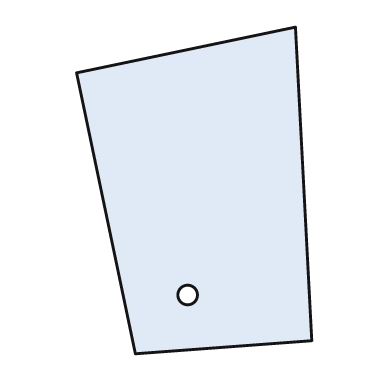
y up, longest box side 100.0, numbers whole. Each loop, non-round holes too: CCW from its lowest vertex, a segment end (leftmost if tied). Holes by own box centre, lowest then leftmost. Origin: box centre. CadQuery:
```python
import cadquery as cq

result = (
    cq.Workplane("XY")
    .moveTo(-18.0, -50.0)
    .lineTo(36.0, -46.0)
    .lineTo(31.0, 50.0)
    .lineTo(-36.0, 36.0)
    .close()
    .moveTo(-2.0, -32.0)
    .circle(3.0)
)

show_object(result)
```